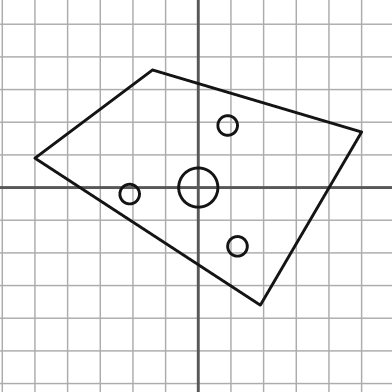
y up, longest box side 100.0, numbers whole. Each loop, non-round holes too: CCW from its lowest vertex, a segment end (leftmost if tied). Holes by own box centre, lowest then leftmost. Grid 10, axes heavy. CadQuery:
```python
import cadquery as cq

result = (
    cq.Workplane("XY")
    .moveTo(19.0, -36.0)
    .lineTo(50.0, 17.0)
    .lineTo(-14.0, 36.0)
    .lineTo(-50.0, 9.0)
    .close()
    .moveTo(12.0, -18.0)
    .circle(3.0)
    .moveTo(-21.0, -2.0)
    .circle(3.0)
    .moveTo(0.0, 0.0)
    .circle(6.0)
    .moveTo(9.0, 19.0)
    .circle(3.0)
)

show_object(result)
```